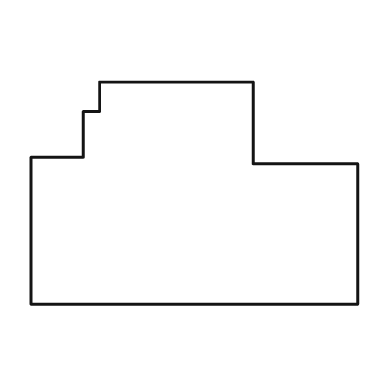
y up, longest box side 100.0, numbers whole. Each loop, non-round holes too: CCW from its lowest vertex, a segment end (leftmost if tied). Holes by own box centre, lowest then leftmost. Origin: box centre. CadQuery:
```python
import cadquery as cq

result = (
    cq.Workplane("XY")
    .moveTo(-50.0, -34.0)
    .lineTo(50.0, -34.0)
    .lineTo(50.0, 9.0)
    .lineTo(18.0, 9.0)
    .lineTo(18.0, 34.0)
    .lineTo(-29.0, 34.0)
    .lineTo(-29.0, 25.0)
    .lineTo(-34.0, 25.0)
    .lineTo(-34.0, 11.0)
    .lineTo(-50.0, 11.0)
    .close()
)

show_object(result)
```